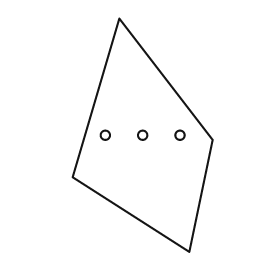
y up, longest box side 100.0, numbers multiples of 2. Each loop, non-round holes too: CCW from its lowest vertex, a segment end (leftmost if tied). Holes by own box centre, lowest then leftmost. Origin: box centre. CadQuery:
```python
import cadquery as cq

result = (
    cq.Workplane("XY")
    .moveTo(20.0, -50.0)
    .lineTo(30.0, -2.0)
    .lineTo(-10.0, 50.0)
    .lineTo(-30.0, -18.0)
    .close()
    .moveTo(-16.0, 0.0)
    .circle(2.0)
    .moveTo(0.0, 0.0)
    .circle(2.0)
    .moveTo(16.0, 0.0)
    .circle(2.0)
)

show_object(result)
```